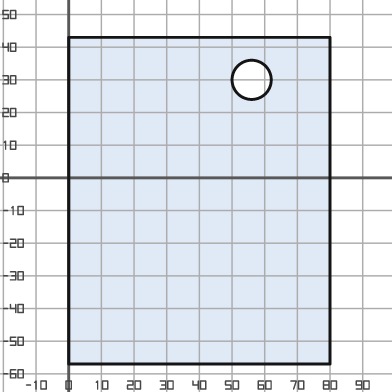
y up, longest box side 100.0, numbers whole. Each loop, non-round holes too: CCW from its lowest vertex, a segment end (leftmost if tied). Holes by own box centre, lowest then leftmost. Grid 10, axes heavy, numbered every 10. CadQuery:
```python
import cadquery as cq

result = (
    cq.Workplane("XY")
    .moveTo(0.0, -57.0)
    .lineTo(80.0, -57.0)
    .lineTo(80.0, 43.0)
    .lineTo(0.0, 43.0)
    .close()
    .moveTo(56.0, 30.0)
    .circle(6.0)
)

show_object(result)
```